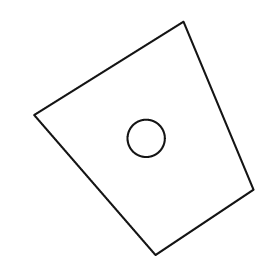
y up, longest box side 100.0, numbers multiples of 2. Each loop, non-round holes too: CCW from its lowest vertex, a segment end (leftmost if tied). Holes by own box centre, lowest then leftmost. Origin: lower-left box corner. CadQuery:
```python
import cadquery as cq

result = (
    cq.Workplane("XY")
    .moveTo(52.0, 0.0)
    .lineTo(94.0, 28.0)
    .lineTo(64.0, 100.0)
    .lineTo(0.0, 60.0)
    .close()
    .moveTo(48.0, 50.0)
    .circle(8.0)
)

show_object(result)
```